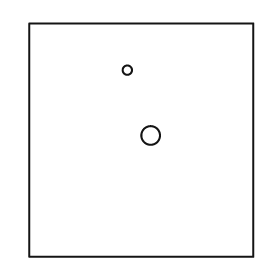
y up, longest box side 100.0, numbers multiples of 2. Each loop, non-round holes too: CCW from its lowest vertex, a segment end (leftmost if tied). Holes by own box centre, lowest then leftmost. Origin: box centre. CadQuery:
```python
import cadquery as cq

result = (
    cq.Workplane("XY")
    .moveTo(-48.0, -50.0)
    .lineTo(48.0, -50.0)
    .lineTo(48.0, 50.0)
    .lineTo(-48.0, 50.0)
    .close()
    .moveTo(4.0, 2.0)
    .circle(4.0)
    .moveTo(-6.0, 30.0)
    .circle(2.0)
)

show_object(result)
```